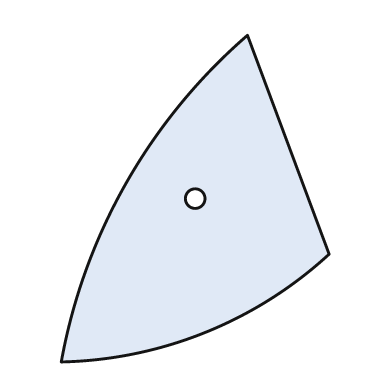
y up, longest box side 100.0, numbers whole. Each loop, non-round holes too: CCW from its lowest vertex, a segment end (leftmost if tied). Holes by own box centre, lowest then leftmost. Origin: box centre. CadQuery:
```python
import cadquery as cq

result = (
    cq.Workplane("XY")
    .moveTo(-41.0, -50.0)
    .threePointArc((3.0, -41.0), (41.0, -17.0))
    .lineTo(16.0, 50.0)
    .threePointArc((-21.0, 5.0), (-41.0, -50.0))
    .close()
    .moveTo(0.0, 0.0)
    .circle(3.0)
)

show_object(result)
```